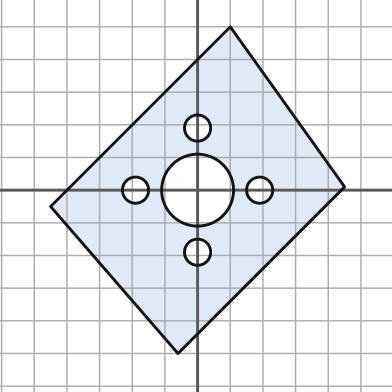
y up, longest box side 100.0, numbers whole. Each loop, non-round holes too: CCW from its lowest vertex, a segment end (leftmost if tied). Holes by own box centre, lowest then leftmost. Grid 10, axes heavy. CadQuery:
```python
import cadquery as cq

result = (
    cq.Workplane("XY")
    .moveTo(-6.0, -50.0)
    .lineTo(45.0, 1.0)
    .lineTo(10.0, 50.0)
    .lineTo(-45.0, -5.0)
    .close()
    .moveTo(0.0, -19.0)
    .circle(4.0)
    .moveTo(-19.0, 0.0)
    .circle(4.0)
    .moveTo(0.0, 0.0)
    .circle(11.0)
    .moveTo(19.0, 0.0)
    .circle(4.0)
    .moveTo(0.0, 19.0)
    .circle(4.0)
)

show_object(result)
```